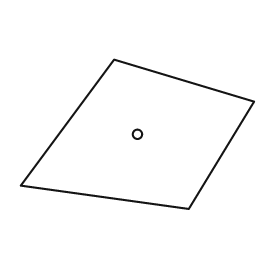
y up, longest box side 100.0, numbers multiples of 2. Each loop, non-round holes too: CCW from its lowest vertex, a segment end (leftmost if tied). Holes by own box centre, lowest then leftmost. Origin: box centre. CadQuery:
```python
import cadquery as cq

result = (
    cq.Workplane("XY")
    .moveTo(22.0, -32.0)
    .lineTo(50.0, 14.0)
    .lineTo(-10.0, 32.0)
    .lineTo(-50.0, -22.0)
    .close()
    .moveTo(0.0, 0.0)
    .circle(2.0)
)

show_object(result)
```